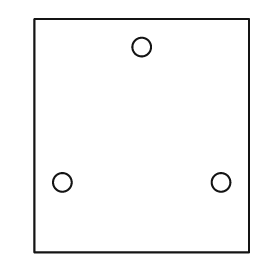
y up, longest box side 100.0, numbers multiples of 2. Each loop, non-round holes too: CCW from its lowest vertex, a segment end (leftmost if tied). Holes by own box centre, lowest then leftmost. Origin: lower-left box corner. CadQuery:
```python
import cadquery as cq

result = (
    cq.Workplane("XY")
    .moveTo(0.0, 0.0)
    .lineTo(92.0, 0.0)
    .lineTo(92.0, 100.0)
    .lineTo(0.0, 100.0)
    .close()
    .moveTo(12.0, 30.0)
    .circle(4.0)
    .moveTo(80.0, 30.0)
    .circle(4.0)
    .moveTo(46.0, 88.0)
    .circle(4.0)
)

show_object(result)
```